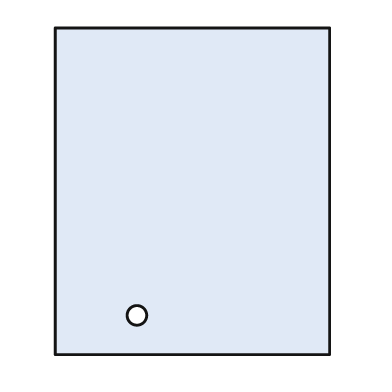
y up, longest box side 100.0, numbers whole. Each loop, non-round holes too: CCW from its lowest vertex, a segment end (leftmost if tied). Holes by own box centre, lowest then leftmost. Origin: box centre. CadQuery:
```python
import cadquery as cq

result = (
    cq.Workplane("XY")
    .moveTo(-42.0, -50.0)
    .lineTo(42.0, -50.0)
    .lineTo(42.0, 50.0)
    .lineTo(-42.0, 50.0)
    .close()
    .moveTo(-17.0, -38.0)
    .circle(3.0)
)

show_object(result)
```